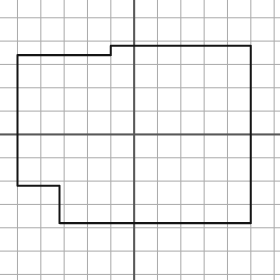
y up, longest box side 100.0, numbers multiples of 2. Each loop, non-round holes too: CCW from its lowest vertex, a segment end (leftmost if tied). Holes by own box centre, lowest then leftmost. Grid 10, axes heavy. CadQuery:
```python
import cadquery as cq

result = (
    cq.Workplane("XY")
    .moveTo(-32.0, -38.0)
    .lineTo(50.0, -38.0)
    .lineTo(50.0, 38.0)
    .lineTo(-10.0, 38.0)
    .lineTo(-10.0, 34.0)
    .lineTo(-50.0, 34.0)
    .lineTo(-50.0, -22.0)
    .lineTo(-32.0, -22.0)
    .close()
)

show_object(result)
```